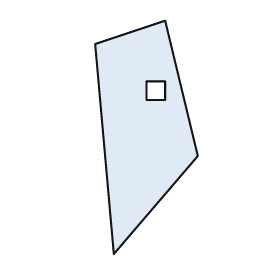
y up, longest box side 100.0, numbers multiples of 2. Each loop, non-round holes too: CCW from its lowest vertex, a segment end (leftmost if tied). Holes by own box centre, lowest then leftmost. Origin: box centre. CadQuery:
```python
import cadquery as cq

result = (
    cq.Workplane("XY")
    .moveTo(-14.0, -50.0)
    .lineTo(22.0, -8.0)
    .lineTo(8.0, 50.0)
    .lineTo(-22.0, 40.0)
    .close()
    .moveTo(0.0, 16.0)
    .lineTo(8.0, 16.0)
    .lineTo(8.0, 24.0)
    .lineTo(0.0, 24.0)
    .close()
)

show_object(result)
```